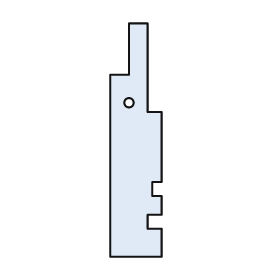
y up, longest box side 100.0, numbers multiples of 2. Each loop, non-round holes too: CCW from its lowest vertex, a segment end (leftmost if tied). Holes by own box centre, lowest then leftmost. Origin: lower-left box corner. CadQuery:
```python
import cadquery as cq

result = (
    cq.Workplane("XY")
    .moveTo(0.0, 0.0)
    .lineTo(22.0, 0.0)
    .lineTo(22.0, 12.0)
    .lineTo(16.0, 12.0)
    .lineTo(16.0, 18.0)
    .lineTo(22.0, 18.0)
    .lineTo(22.0, 26.0)
    .lineTo(18.0, 26.0)
    .lineTo(18.0, 32.0)
    .lineTo(22.0, 32.0)
    .lineTo(22.0, 62.0)
    .lineTo(16.0, 62.0)
    .lineTo(16.0, 100.0)
    .lineTo(8.0, 100.0)
    .lineTo(8.0, 78.0)
    .lineTo(0.0, 78.0)
    .close()
    .moveTo(8.0, 66.0)
    .circle(2.0)
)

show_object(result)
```